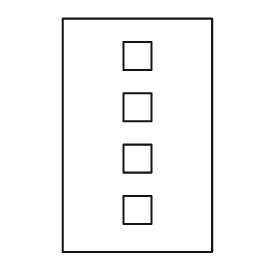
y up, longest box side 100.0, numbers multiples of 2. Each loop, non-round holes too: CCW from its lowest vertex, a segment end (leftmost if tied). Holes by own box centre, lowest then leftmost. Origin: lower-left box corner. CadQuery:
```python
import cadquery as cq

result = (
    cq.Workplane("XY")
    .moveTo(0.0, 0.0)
    .lineTo(64.0, 0.0)
    .lineTo(64.0, 100.0)
    .lineTo(0.0, 100.0)
    .close()
    .moveTo(26.0, 12.0)
    .lineTo(38.0, 12.0)
    .lineTo(38.0, 24.0)
    .lineTo(26.0, 24.0)
    .close()
    .moveTo(26.0, 34.0)
    .lineTo(38.0, 34.0)
    .lineTo(38.0, 46.0)
    .lineTo(26.0, 46.0)
    .close()
    .moveTo(26.0, 56.0)
    .lineTo(38.0, 56.0)
    .lineTo(38.0, 68.0)
    .lineTo(26.0, 68.0)
    .close()
    .moveTo(26.0, 78.0)
    .lineTo(38.0, 78.0)
    .lineTo(38.0, 90.0)
    .lineTo(26.0, 90.0)
    .close()
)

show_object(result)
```